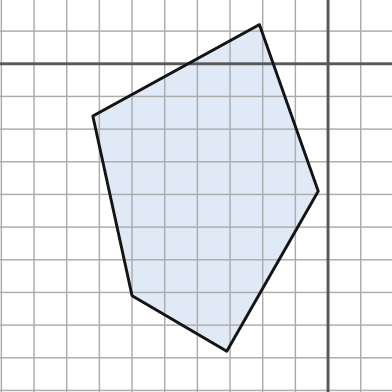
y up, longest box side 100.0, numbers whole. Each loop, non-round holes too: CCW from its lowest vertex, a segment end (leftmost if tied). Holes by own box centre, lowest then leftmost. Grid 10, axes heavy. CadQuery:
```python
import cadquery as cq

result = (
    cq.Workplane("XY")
    .moveTo(-31.0, -88.0)
    .lineTo(-3.0, -39.0)
    .lineTo(-21.0, 12.0)
    .lineTo(-72.0, -16.0)
    .lineTo(-60.0, -71.0)
    .close()
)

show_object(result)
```